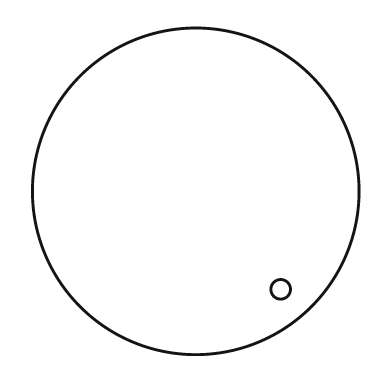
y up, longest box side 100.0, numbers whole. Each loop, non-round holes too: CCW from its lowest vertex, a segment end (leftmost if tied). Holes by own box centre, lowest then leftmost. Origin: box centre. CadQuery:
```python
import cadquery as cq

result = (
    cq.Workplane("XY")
    .moveTo(0.0, 0.0)
    .circle(50.0)
    .moveTo(26.0, -30.0)
    .circle(3.0)
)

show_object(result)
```